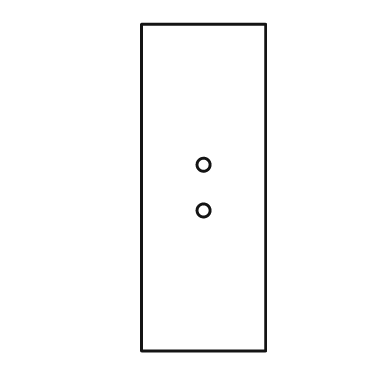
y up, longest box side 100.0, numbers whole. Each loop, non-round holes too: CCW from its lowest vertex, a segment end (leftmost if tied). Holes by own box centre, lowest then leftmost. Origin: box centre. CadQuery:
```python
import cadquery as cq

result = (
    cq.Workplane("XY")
    .moveTo(-19.0, -50.0)
    .lineTo(19.0, -50.0)
    .lineTo(19.0, 50.0)
    .lineTo(-19.0, 50.0)
    .close()
    .moveTo(0.0, -7.0)
    .circle(2.0)
    .moveTo(0.0, 7.0)
    .circle(2.0)
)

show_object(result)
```